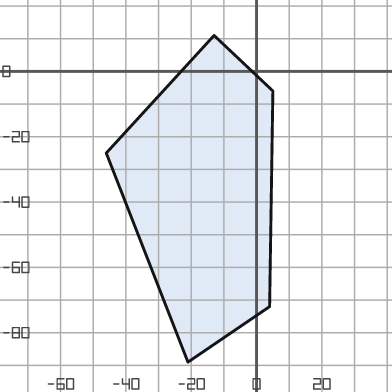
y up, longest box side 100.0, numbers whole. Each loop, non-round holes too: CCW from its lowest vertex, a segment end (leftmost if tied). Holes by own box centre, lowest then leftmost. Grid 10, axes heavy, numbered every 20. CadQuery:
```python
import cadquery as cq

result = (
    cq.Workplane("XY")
    .moveTo(-21.0, -89.0)
    .lineTo(4.0, -72.0)
    .lineTo(5.0, -6.0)
    .lineTo(-13.0, 11.0)
    .lineTo(-46.0, -25.0)
    .close()
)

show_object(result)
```